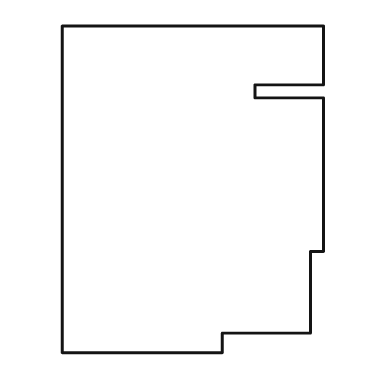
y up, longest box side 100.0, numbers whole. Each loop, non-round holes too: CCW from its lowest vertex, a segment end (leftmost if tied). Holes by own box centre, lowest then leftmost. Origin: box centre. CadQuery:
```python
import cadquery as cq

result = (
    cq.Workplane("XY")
    .moveTo(-40.0, -50.0)
    .lineTo(9.0, -50.0)
    .lineTo(9.0, -44.0)
    .lineTo(36.0, -44.0)
    .lineTo(36.0, -19.0)
    .lineTo(40.0, -19.0)
    .lineTo(40.0, 28.0)
    .lineTo(19.0, 28.0)
    .lineTo(19.0, 32.0)
    .lineTo(40.0, 32.0)
    .lineTo(40.0, 50.0)
    .lineTo(-40.0, 50.0)
    .close()
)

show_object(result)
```